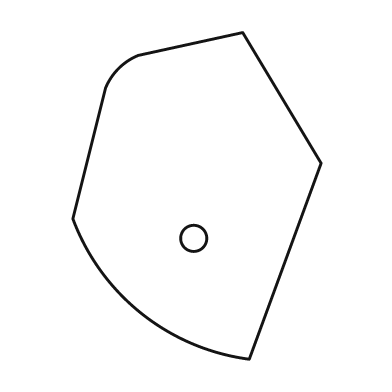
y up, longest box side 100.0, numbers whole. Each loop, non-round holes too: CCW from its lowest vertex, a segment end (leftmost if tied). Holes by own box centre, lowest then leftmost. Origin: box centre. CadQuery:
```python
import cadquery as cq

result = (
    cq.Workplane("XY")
    .moveTo(16.0, -50.0)
    .lineTo(38.0, 10.0)
    .lineTo(14.0, 50.0)
    .lineTo(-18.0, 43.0)
    .threePointArc((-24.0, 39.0), (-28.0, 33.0))
    .lineTo(-38.0, -7.0)
    .threePointArc((-17.0, -36.0), (16.0, -50.0))
    .close()
    .moveTo(-1.0, -13.0)
    .circle(4.0)
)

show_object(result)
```